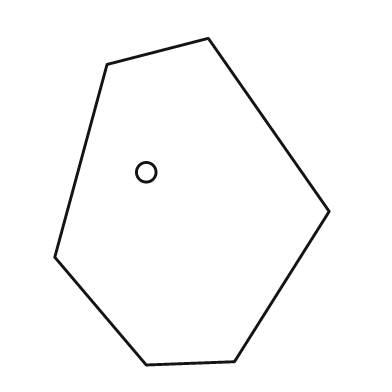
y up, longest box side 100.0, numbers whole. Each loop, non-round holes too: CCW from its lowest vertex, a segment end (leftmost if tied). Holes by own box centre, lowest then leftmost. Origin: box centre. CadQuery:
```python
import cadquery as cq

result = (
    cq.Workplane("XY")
    .moveTo(-14.0, -50.0)
    .lineTo(13.0, -49.0)
    .lineTo(42.0, -3.0)
    .lineTo(5.0, 50.0)
    .lineTo(-26.0, 42.0)
    .lineTo(-42.0, -17.0)
    .close()
    .moveTo(-14.0, 9.0)
    .circle(3.0)
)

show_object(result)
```